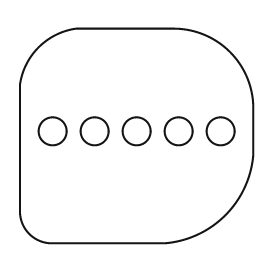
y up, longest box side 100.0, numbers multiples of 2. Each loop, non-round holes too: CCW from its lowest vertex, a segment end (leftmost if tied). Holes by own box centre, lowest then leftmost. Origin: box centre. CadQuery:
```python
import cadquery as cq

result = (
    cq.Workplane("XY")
    .moveTo(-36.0, -46.0)
    .lineTo(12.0, -46.0)
    .threePointArc((38.0, -34.0), (50.0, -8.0))
    .lineTo(50.0, 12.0)
    .threePointArc((40.0, 36.0), (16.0, 46.0))
    .lineTo(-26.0, 46.0)
    .threePointArc((-42.0, 38.0), (-50.0, 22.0))
    .lineTo(-50.0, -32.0)
    .threePointArc((-46.0, -42.0), (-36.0, -46.0))
    .close()
    .moveTo(-36.0, 2.0)
    .circle(6.0)
    .moveTo(-18.0, 2.0)
    .circle(6.0)
    .moveTo(0.0, 2.0)
    .circle(6.0)
    .moveTo(18.0, 2.0)
    .circle(6.0)
    .moveTo(36.0, 2.0)
    .circle(6.0)
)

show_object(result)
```